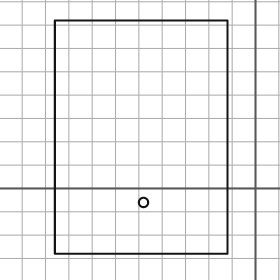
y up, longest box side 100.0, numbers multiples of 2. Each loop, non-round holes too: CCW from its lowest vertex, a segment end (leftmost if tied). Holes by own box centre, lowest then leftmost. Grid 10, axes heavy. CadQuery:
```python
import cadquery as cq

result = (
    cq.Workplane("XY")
    .moveTo(-86.0, -28.0)
    .lineTo(-12.0, -28.0)
    .lineTo(-12.0, 72.0)
    .lineTo(-86.0, 72.0)
    .close()
    .moveTo(-48.0, -6.0)
    .circle(2.0)
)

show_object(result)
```